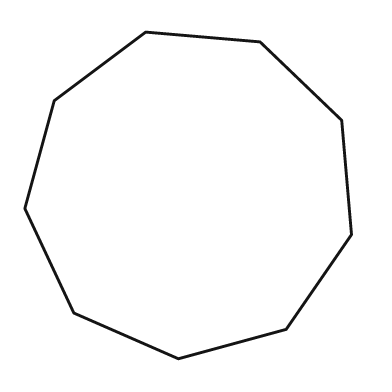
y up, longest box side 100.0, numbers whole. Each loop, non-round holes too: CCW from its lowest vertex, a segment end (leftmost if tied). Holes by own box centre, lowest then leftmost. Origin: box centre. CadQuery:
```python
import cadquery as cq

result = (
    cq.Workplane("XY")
    .moveTo(-3.0, -50.0)
    .lineTo(30.0, -41.0)
    .lineTo(50.0, -12.0)
    .lineTo(47.0, 23.0)
    .lineTo(22.0, 47.0)
    .lineTo(-13.0, 50.0)
    .lineTo(-41.0, 29.0)
    .lineTo(-50.0, -4.0)
    .lineTo(-35.0, -36.0)
    .close()
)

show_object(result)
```